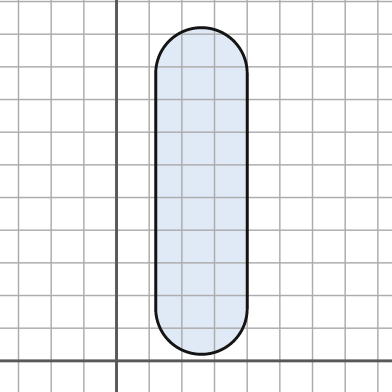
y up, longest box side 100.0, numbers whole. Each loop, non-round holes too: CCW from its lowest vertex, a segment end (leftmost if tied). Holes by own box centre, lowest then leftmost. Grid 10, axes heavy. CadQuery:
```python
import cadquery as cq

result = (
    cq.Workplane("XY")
    .moveTo(12.0, 16.0)
    .threePointArc((26.0, 2.0), (40.0, 16.0))
    .lineTo(40.0, 88.0)
    .threePointArc((26.0, 102.0), (12.0, 88.0))
    .close()
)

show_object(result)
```